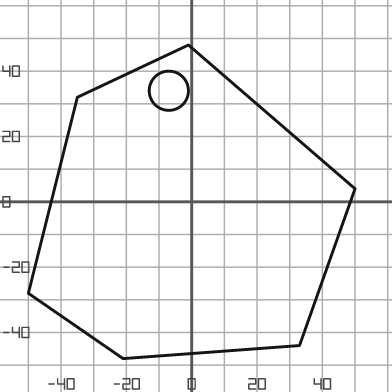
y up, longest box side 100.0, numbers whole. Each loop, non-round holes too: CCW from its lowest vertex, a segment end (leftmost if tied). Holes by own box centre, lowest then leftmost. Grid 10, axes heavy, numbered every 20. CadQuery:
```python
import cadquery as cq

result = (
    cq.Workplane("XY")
    .moveTo(-21.0, -48.0)
    .lineTo(33.0, -44.0)
    .lineTo(50.0, 4.0)
    .lineTo(-1.0, 48.0)
    .lineTo(-35.0, 32.0)
    .lineTo(-50.0, -28.0)
    .close()
    .moveTo(-7.0, 34.0)
    .circle(6.0)
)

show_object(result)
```